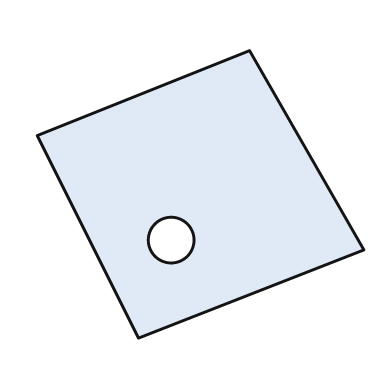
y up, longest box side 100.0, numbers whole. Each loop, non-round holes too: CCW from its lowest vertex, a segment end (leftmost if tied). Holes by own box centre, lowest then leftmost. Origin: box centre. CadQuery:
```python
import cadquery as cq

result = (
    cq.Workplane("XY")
    .moveTo(-19.0, -44.0)
    .lineTo(50.0, -17.0)
    .lineTo(15.0, 44.0)
    .lineTo(-50.0, 18.0)
    .close()
    .moveTo(-9.0, -14.0)
    .circle(7.0)
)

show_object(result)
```